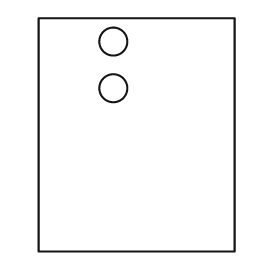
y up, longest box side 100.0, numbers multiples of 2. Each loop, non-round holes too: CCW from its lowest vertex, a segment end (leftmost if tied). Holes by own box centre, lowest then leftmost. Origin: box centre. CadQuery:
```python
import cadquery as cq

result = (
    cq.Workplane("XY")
    .moveTo(-42.0, -50.0)
    .lineTo(42.0, -50.0)
    .lineTo(42.0, 50.0)
    .lineTo(-42.0, 50.0)
    .close()
    .moveTo(-10.0, 20.0)
    .circle(6.0)
    .moveTo(-10.0, 40.0)
    .circle(6.0)
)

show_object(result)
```